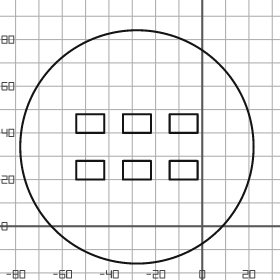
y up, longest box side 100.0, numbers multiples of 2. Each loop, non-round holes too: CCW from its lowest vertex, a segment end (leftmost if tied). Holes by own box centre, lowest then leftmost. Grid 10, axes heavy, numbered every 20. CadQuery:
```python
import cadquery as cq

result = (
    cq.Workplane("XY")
    .moveTo(-28.0, 34.0)
    .circle(50.0)
    .moveTo(-54.0, 20.0)
    .lineTo(-42.0, 20.0)
    .lineTo(-42.0, 28.0)
    .lineTo(-54.0, 28.0)
    .close()
    .moveTo(-34.0, 20.0)
    .lineTo(-22.0, 20.0)
    .lineTo(-22.0, 28.0)
    .lineTo(-34.0, 28.0)
    .close()
    .moveTo(-14.0, 20.0)
    .lineTo(-2.0, 20.0)
    .lineTo(-2.0, 28.0)
    .lineTo(-14.0, 28.0)
    .close()
    .moveTo(-54.0, 40.0)
    .lineTo(-42.0, 40.0)
    .lineTo(-42.0, 48.0)
    .lineTo(-54.0, 48.0)
    .close()
    .moveTo(-34.0, 40.0)
    .lineTo(-22.0, 40.0)
    .lineTo(-22.0, 48.0)
    .lineTo(-34.0, 48.0)
    .close()
    .moveTo(-14.0, 40.0)
    .lineTo(-2.0, 40.0)
    .lineTo(-2.0, 48.0)
    .lineTo(-14.0, 48.0)
    .close()
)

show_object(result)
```